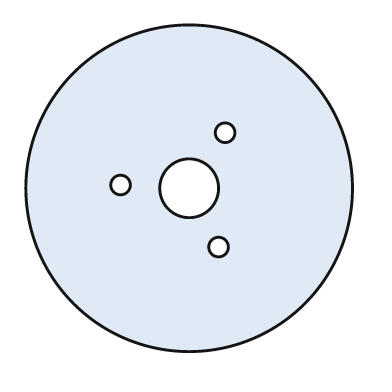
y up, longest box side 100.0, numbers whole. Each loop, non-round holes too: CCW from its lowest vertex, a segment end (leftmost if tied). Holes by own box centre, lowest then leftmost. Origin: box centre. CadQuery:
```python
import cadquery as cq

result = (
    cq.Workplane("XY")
    .moveTo(0.0, 0.0)
    .circle(50.0)
    .moveTo(9.0, -18.0)
    .circle(3.0)
    .moveTo(0.0, 0.0)
    .circle(9.0)
    .moveTo(-21.0, 1.0)
    .circle(3.0)
    .moveTo(11.0, 17.0)
    .circle(3.0)
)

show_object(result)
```